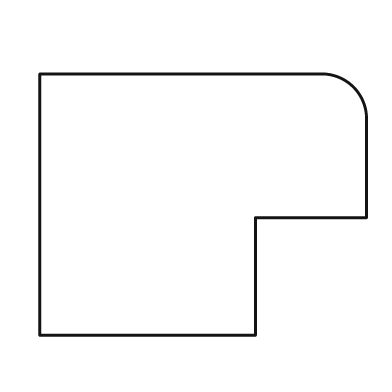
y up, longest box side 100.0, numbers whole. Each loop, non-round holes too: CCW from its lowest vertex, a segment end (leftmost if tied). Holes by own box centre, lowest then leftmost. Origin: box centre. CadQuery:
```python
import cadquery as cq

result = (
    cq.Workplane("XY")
    .moveTo(-50.0, -40.0)
    .lineTo(16.0, -40.0)
    .lineTo(16.0, -4.0)
    .lineTo(50.0, -4.0)
    .lineTo(50.0, 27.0)
    .threePointArc((46.0, 36.0), (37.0, 40.0))
    .lineTo(-50.0, 40.0)
    .close()
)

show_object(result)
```